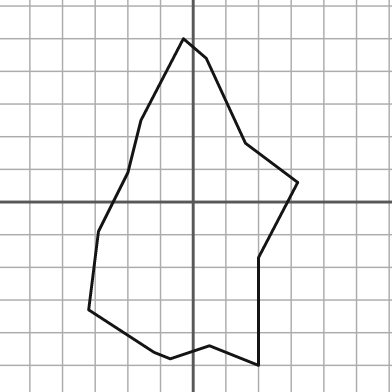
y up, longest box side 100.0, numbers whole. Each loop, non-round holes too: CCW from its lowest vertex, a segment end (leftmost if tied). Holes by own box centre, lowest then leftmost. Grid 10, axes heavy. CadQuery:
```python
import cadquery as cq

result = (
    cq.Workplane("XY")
    .moveTo(20.0, -50.0)
    .lineTo(20.0, -17.0)
    .lineTo(32.0, 6.0)
    .lineTo(16.0, 18.0)
    .lineTo(4.0, 44.0)
    .lineTo(-3.0, 50.0)
    .lineTo(-16.0, 25.0)
    .lineTo(-20.0, 9.0)
    .lineTo(-29.0, -9.0)
    .lineTo(-32.0, -33.0)
    .lineTo(-12.0, -46.0)
    .lineTo(-7.0, -48.0)
    .lineTo(5.0, -44.0)
    .close()
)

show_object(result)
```